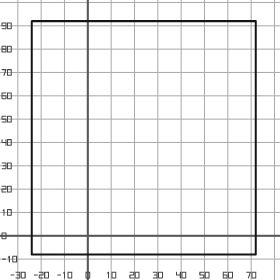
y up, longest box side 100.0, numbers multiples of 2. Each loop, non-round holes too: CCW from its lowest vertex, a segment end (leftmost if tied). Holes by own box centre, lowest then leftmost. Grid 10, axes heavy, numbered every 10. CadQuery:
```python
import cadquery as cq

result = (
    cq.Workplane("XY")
    .moveTo(-24.0, -8.0)
    .lineTo(72.0, -8.0)
    .lineTo(72.0, 92.0)
    .lineTo(-24.0, 92.0)
    .close()
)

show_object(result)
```